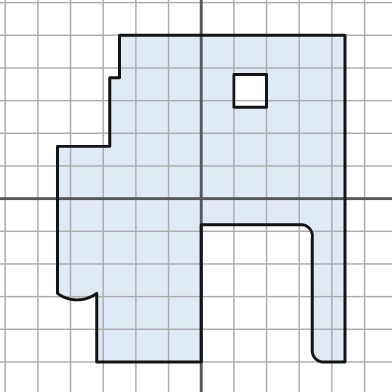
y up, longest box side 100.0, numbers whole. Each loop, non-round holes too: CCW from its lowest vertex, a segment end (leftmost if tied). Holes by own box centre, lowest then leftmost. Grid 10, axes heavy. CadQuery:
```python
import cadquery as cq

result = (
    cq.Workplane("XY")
    .moveTo(-32.0, -50.0)
    .lineTo(0.0, -50.0)
    .lineTo(0.0, -8.0)
    .lineTo(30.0, -8.0)
    .threePointArc((33.0, -9.0), (34.0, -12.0))
    .lineTo(34.0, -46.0)
    .threePointArc((35.0, -49.0), (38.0, -50.0))
    .lineTo(44.0, -50.0)
    .lineTo(44.0, 50.0)
    .lineTo(-25.0, 50.0)
    .lineTo(-25.0, 37.0)
    .lineTo(-28.0, 37.0)
    .lineTo(-28.0, 16.0)
    .lineTo(-44.0, 16.0)
    .lineTo(-44.0, -29.0)
    .threePointArc((-38.0, -31.0), (-32.0, -29.0))
    .close()
    .moveTo(10.0, 28.0)
    .lineTo(20.0, 28.0)
    .lineTo(20.0, 38.0)
    .lineTo(10.0, 38.0)
    .close()
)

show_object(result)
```